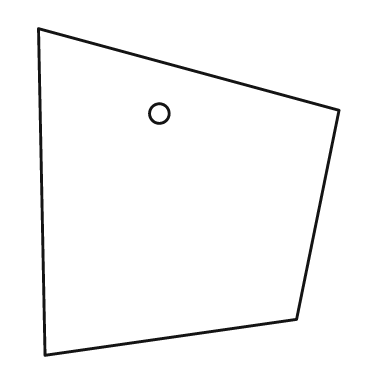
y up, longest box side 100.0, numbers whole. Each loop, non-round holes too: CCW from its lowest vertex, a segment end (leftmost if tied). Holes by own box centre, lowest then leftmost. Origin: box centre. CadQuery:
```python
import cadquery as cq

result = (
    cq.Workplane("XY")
    .moveTo(-44.0, -50.0)
    .lineTo(33.0, -39.0)
    .lineTo(46.0, 25.0)
    .lineTo(-46.0, 50.0)
    .close()
    .moveTo(-9.0, 24.0)
    .circle(3.0)
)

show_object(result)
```